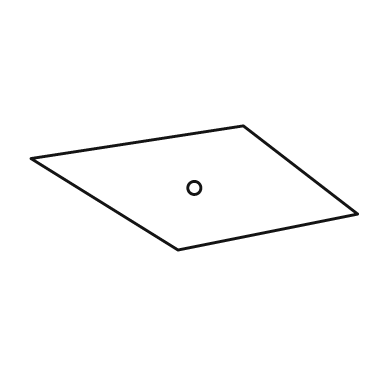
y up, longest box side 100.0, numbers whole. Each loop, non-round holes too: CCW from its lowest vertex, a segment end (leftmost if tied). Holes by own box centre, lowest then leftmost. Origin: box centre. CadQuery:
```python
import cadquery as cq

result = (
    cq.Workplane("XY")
    .moveTo(-5.0, -19.0)
    .lineTo(50.0, -8.0)
    .lineTo(15.0, 19.0)
    .lineTo(-50.0, 9.0)
    .close()
    .moveTo(0.0, 0.0)
    .circle(2.0)
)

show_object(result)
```